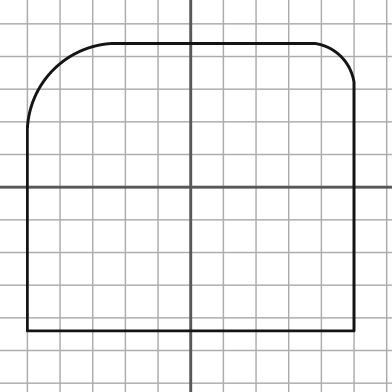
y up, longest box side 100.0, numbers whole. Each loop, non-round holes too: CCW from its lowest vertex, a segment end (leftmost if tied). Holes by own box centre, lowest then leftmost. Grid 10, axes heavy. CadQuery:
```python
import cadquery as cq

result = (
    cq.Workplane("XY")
    .moveTo(-50.0, -44.0)
    .lineTo(50.0, -44.0)
    .lineTo(50.0, 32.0)
    .threePointArc((46.0, 40.0), (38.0, 44.0))
    .lineTo(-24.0, 44.0)
    .threePointArc((-42.0, 36.0), (-50.0, 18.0))
    .close()
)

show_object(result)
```